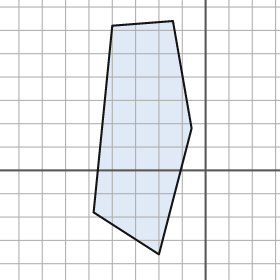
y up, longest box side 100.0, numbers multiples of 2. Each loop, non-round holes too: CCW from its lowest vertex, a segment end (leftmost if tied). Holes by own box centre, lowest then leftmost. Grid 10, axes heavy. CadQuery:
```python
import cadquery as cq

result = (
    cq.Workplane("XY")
    .moveTo(-20.0, -36.0)
    .lineTo(-6.0, 18.0)
    .lineTo(-14.0, 64.0)
    .lineTo(-40.0, 62.0)
    .lineTo(-48.0, -18.0)
    .close()
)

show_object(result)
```